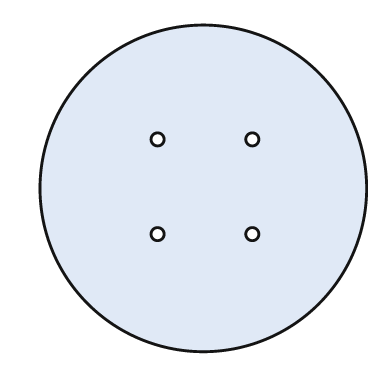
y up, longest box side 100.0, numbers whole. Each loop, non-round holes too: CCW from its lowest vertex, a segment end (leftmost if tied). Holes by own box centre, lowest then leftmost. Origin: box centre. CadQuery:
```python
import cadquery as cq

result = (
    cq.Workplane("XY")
    .moveTo(0.0, 0.0)
    .circle(50.0)
    .moveTo(-14.0, -14.0)
    .circle(2.0)
    .moveTo(15.0, -14.0)
    .circle(2.0)
    .moveTo(-14.0, 15.0)
    .circle(2.0)
    .moveTo(15.0, 15.0)
    .circle(2.0)
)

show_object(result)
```